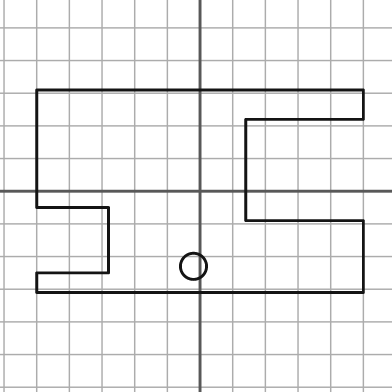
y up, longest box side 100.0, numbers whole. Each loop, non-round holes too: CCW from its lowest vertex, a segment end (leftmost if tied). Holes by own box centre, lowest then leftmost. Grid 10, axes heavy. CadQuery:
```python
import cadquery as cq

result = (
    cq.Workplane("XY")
    .moveTo(-50.0, -31.0)
    .lineTo(50.0, -31.0)
    .lineTo(50.0, -9.0)
    .lineTo(14.0, -9.0)
    .lineTo(14.0, 22.0)
    .lineTo(50.0, 22.0)
    .lineTo(50.0, 31.0)
    .lineTo(-50.0, 31.0)
    .lineTo(-50.0, -5.0)
    .lineTo(-28.0, -5.0)
    .lineTo(-28.0, -25.0)
    .lineTo(-50.0, -25.0)
    .close()
    .moveTo(-2.0, -23.0)
    .circle(4.0)
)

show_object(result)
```